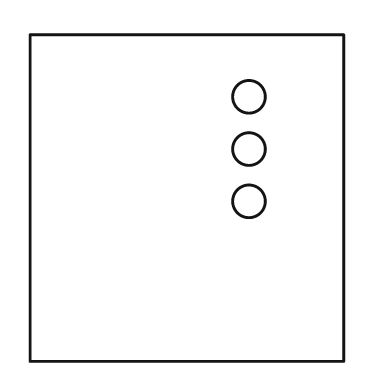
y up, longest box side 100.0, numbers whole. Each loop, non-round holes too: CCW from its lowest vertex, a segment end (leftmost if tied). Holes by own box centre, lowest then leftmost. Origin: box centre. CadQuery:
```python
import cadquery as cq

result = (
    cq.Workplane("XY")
    .moveTo(-48.0, -50.0)
    .lineTo(48.0, -50.0)
    .lineTo(48.0, 50.0)
    .lineTo(-48.0, 50.0)
    .close()
    .moveTo(19.0, -1.0)
    .circle(5.0)
    .moveTo(19.0, 15.0)
    .circle(5.0)
    .moveTo(19.0, 31.0)
    .circle(5.0)
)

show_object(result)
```